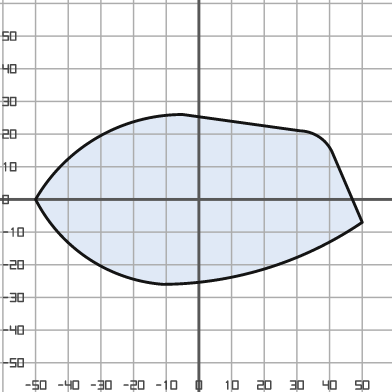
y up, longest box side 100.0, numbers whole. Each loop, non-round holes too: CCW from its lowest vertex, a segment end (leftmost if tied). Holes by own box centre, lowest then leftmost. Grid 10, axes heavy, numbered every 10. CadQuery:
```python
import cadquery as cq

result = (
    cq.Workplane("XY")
    .moveTo(-11.0, -26.0)
    .threePointArc((21.0, -21.0), (50.0, -7.0))
    .lineTo(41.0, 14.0)
    .threePointArc((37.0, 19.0), (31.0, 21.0))
    .lineTo(-5.0, 26.0)
    .threePointArc((-31.0, 19.0), (-50.0, 0.0))
    .threePointArc((-34.0, -18.0), (-11.0, -26.0))
    .close()
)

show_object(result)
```